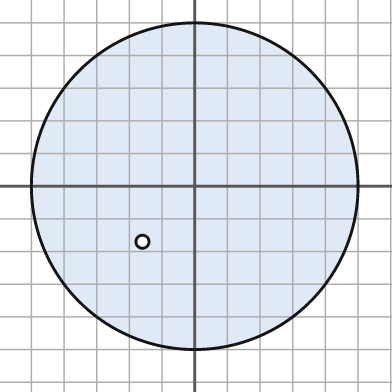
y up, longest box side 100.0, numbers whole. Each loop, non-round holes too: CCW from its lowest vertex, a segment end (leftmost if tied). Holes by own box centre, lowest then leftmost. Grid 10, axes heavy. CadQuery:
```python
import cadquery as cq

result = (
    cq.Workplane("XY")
    .moveTo(0.0, 0.0)
    .circle(50.0)
    .moveTo(-16.0, -17.0)
    .circle(2.0)
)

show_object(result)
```